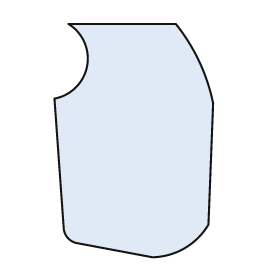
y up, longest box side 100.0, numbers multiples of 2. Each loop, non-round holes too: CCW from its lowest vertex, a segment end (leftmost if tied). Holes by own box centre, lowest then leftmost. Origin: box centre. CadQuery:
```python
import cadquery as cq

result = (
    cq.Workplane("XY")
    .moveTo(8.0, -50.0)
    .threePointArc((22.0, -46.0), (32.0, -36.0))
    .lineTo(34.0, 16.0)
    .threePointArc((28.0, 34.0), (18.0, 50.0))
    .lineTo(-28.0, 50.0)
    .threePointArc((-20.0, 32.0), (-34.0, 18.0))
    .lineTo(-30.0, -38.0)
    .threePointArc((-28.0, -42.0), (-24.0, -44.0))
    .close()
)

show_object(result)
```